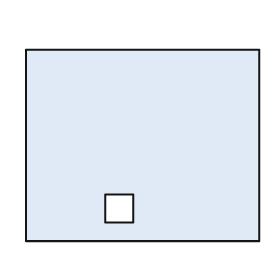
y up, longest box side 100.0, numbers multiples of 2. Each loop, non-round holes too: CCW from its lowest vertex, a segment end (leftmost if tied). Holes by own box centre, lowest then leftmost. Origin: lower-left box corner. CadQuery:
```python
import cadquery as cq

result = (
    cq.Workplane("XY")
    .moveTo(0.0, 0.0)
    .lineTo(100.0, 0.0)
    .lineTo(100.0, 82.0)
    .lineTo(0.0, 82.0)
    .close()
    .moveTo(34.0, 8.0)
    .lineTo(46.0, 8.0)
    .lineTo(46.0, 20.0)
    .lineTo(34.0, 20.0)
    .close()
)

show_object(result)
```